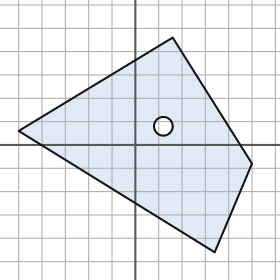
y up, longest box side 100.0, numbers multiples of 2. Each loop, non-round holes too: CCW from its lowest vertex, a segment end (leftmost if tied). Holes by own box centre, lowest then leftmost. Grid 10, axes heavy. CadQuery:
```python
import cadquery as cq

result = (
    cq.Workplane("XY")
    .moveTo(34.0, -46.0)
    .lineTo(50.0, -8.0)
    .lineTo(16.0, 46.0)
    .lineTo(-50.0, 6.0)
    .close()
    .moveTo(12.0, 8.0)
    .circle(4.0)
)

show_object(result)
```